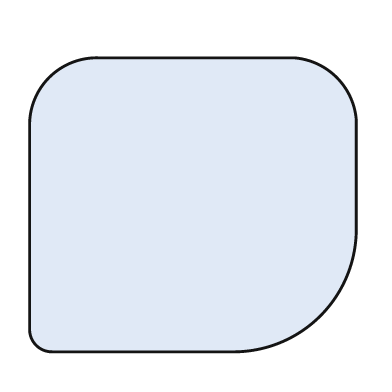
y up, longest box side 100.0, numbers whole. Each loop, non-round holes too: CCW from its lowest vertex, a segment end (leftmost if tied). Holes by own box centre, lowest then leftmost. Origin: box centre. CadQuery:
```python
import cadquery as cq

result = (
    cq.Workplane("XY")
    .moveTo(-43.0, -45.0)
    .lineTo(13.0, -45.0)
    .threePointArc((39.0, -34.0), (50.0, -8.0))
    .lineTo(50.0, 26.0)
    .threePointArc((44.0, 39.0), (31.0, 45.0))
    .lineTo(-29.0, 45.0)
    .threePointArc((-44.0, 39.0), (-50.0, 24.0))
    .lineTo(-50.0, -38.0)
    .threePointArc((-48.0, -43.0), (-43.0, -45.0))
    .close()
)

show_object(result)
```